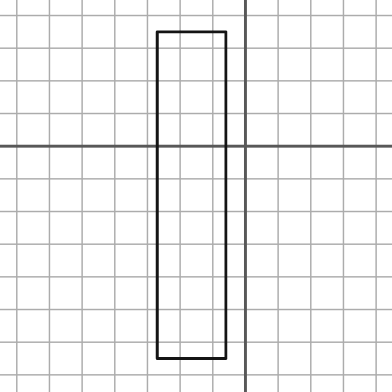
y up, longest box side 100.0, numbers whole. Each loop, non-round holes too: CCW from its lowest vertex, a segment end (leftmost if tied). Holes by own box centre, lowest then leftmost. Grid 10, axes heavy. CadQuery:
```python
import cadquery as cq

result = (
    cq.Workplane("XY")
    .moveTo(-27.0, -65.0)
    .lineTo(-6.0, -65.0)
    .lineTo(-6.0, 35.0)
    .lineTo(-27.0, 35.0)
    .close()
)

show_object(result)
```